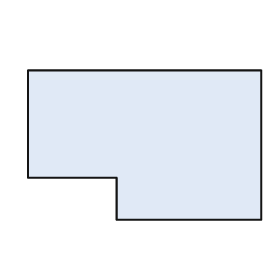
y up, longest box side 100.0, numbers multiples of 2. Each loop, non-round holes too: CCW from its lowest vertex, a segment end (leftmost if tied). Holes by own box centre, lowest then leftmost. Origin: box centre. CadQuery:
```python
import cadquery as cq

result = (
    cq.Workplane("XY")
    .moveTo(-12.0, -32.0)
    .lineTo(50.0, -32.0)
    .lineTo(50.0, 32.0)
    .lineTo(-50.0, 32.0)
    .lineTo(-50.0, -14.0)
    .lineTo(-12.0, -14.0)
    .close()
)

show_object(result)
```